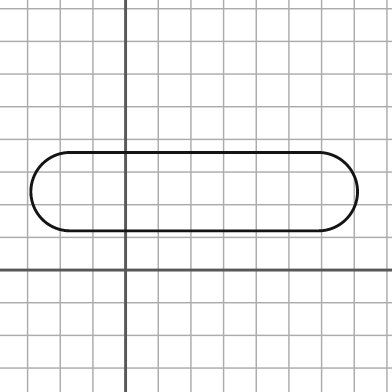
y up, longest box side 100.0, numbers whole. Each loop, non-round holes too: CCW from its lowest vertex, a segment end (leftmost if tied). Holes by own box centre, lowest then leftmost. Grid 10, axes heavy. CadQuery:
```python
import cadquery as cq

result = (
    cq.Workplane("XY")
    .moveTo(-17.0, 12.0)
    .lineTo(59.0, 12.0)
    .threePointArc((71.0, 24.0), (59.0, 36.0))
    .lineTo(-17.0, 36.0)
    .threePointArc((-29.0, 24.0), (-17.0, 12.0))
    .close()
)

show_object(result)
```